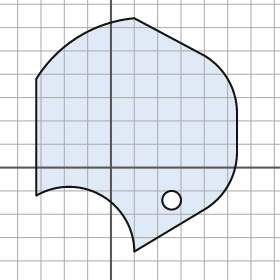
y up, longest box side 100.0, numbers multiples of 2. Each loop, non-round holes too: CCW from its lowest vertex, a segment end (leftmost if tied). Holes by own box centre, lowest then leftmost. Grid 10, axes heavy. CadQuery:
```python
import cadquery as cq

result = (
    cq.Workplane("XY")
    .moveTo(10.0, -36.0)
    .lineTo(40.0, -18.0)
    .threePointArc((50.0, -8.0), (54.0, 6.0))
    .lineTo(54.0, 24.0)
    .threePointArc((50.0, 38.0), (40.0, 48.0))
    .lineTo(10.0, 64.0)
    .threePointArc((-14.0, 56.0), (-32.0, 38.0))
    .lineTo(-32.0, -12.0)
    .threePointArc((-4.0, -12.0), (10.0, -36.0))
    .close()
    .moveTo(26.0, -14.0)
    .circle(4.0)
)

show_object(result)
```